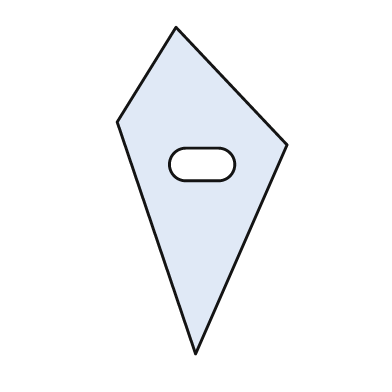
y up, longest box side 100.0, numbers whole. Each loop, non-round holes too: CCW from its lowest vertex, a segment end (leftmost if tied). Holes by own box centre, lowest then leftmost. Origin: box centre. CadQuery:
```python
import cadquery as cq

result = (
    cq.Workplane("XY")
    .moveTo(-2.0, -50.0)
    .lineTo(26.0, 14.0)
    .lineTo(-8.0, 50.0)
    .lineTo(-26.0, 21.0)
    .close()
    .moveTo(-5.0, 3.0)
    .lineTo(5.0, 3.0)
    .threePointArc((10.0, 8.0), (5.0, 13.0))
    .lineTo(-5.0, 13.0)
    .threePointArc((-10.0, 8.0), (-5.0, 3.0))
    .close()
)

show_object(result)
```